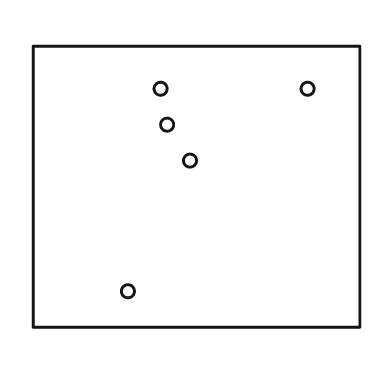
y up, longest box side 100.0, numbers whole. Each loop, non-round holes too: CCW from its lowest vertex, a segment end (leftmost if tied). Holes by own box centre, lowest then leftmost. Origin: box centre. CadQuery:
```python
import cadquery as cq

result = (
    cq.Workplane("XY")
    .moveTo(-50.0, -43.0)
    .lineTo(50.0, -43.0)
    .lineTo(50.0, 43.0)
    .lineTo(-50.0, 43.0)
    .close()
    .moveTo(-21.0, -32.0)
    .circle(2.0)
    .moveTo(-2.0, 8.0)
    .circle(2.0)
    .moveTo(-9.0, 19.0)
    .circle(2.0)
    .moveTo(-11.0, 30.0)
    .circle(2.0)
    .moveTo(34.0, 30.0)
    .circle(2.0)
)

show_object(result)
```